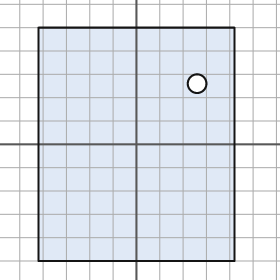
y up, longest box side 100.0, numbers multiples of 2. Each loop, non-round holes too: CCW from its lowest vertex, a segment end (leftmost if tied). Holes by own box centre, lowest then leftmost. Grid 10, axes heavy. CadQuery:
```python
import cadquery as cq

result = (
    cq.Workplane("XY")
    .moveTo(-42.0, -50.0)
    .lineTo(42.0, -50.0)
    .lineTo(42.0, 50.0)
    .lineTo(-42.0, 50.0)
    .close()
    .moveTo(26.0, 26.0)
    .circle(4.0)
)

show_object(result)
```